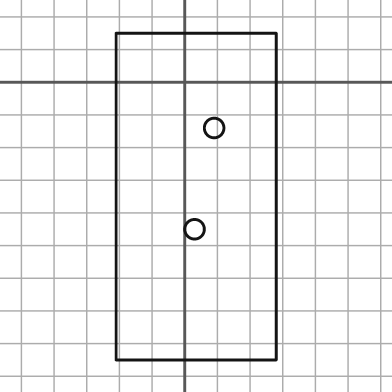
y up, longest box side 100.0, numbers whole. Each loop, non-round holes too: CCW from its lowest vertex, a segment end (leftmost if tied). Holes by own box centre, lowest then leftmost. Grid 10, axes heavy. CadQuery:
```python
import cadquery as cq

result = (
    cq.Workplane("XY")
    .moveTo(-21.0, -85.0)
    .lineTo(28.0, -85.0)
    .lineTo(28.0, 15.0)
    .lineTo(-21.0, 15.0)
    .close()
    .moveTo(3.0, -45.0)
    .circle(3.0)
    .moveTo(9.0, -14.0)
    .circle(3.0)
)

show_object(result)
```